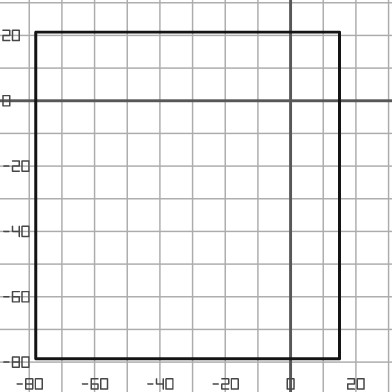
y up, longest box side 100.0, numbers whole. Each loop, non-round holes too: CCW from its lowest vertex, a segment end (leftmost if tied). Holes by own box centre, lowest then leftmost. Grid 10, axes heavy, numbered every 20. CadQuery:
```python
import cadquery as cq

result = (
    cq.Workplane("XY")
    .moveTo(-78.0, -79.0)
    .lineTo(15.0, -79.0)
    .lineTo(15.0, 21.0)
    .lineTo(-78.0, 21.0)
    .close()
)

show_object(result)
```